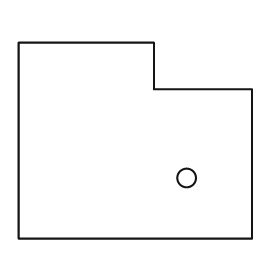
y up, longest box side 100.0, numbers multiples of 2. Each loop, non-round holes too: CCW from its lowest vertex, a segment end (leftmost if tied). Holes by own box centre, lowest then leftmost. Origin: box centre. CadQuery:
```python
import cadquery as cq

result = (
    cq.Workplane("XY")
    .moveTo(-50.0, -42.0)
    .lineTo(50.0, -42.0)
    .lineTo(50.0, 22.0)
    .lineTo(8.0, 22.0)
    .lineTo(8.0, 42.0)
    .lineTo(-50.0, 42.0)
    .close()
    .moveTo(22.0, -16.0)
    .circle(4.0)
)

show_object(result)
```